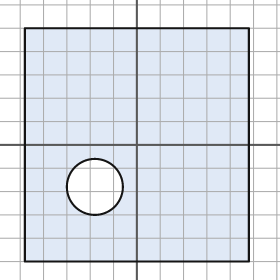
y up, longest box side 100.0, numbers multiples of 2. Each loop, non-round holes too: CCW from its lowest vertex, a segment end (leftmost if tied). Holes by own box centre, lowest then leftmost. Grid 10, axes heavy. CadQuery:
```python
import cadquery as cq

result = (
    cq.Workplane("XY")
    .moveTo(-48.0, -50.0)
    .lineTo(48.0, -50.0)
    .lineTo(48.0, 50.0)
    .lineTo(-48.0, 50.0)
    .close()
    .moveTo(-18.0, -18.0)
    .circle(12.0)
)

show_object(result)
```